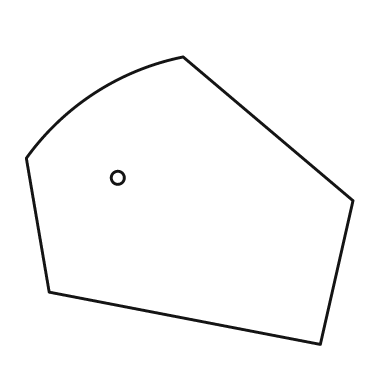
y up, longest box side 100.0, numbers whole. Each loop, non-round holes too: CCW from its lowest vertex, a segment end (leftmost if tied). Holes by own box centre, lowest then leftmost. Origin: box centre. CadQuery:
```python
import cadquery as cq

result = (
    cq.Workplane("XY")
    .moveTo(40.0, -44.0)
    .lineTo(50.0, 0.0)
    .lineTo(-2.0, 44.0)
    .threePointArc((-29.0, 33.0), (-50.0, 13.0))
    .lineTo(-43.0, -28.0)
    .close()
    .moveTo(-22.0, 7.0)
    .circle(2.0)
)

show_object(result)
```